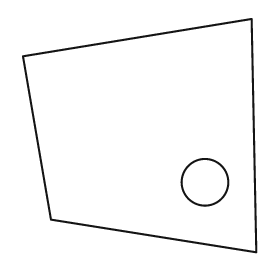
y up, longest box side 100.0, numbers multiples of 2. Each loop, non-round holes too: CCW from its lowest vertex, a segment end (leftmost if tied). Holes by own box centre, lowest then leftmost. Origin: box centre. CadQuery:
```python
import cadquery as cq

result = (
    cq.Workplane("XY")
    .moveTo(50.0, -50.0)
    .lineTo(48.0, 50.0)
    .lineTo(-50.0, 34.0)
    .lineTo(-38.0, -36.0)
    .close()
    .moveTo(28.0, -20.0)
    .circle(10.0)
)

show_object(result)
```